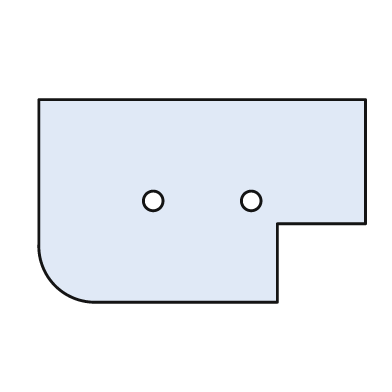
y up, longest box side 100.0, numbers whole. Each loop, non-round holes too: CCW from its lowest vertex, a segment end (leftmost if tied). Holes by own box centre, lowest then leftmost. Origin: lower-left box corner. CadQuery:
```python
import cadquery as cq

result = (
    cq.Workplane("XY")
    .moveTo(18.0, 0.0)
    .lineTo(73.0, 0.0)
    .lineTo(73.0, 24.0)
    .lineTo(100.0, 24.0)
    .lineTo(100.0, 62.0)
    .lineTo(0.0, 62.0)
    .lineTo(0.0, 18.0)
    .threePointArc((5.0, 5.0), (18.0, 0.0))
    .close()
    .moveTo(35.0, 31.0)
    .circle(3.0)
    .moveTo(65.0, 31.0)
    .circle(3.0)
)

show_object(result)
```